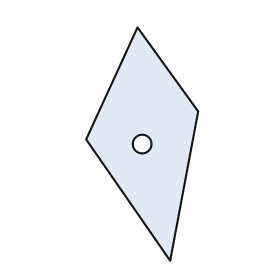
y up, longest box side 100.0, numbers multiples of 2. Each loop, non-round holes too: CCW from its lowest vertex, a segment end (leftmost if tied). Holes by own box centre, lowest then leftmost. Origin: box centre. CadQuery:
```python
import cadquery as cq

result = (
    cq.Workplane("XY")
    .moveTo(12.0, -50.0)
    .lineTo(24.0, 14.0)
    .lineTo(-2.0, 50.0)
    .lineTo(-24.0, 2.0)
    .close()
    .moveTo(0.0, 0.0)
    .circle(4.0)
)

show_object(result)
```